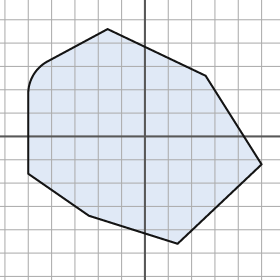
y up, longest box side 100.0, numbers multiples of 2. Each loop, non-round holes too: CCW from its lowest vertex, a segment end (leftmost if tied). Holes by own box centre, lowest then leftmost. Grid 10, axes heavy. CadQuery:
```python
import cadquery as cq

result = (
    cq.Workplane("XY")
    .moveTo(14.0, -46.0)
    .lineTo(50.0, -12.0)
    .lineTo(26.0, 26.0)
    .lineTo(-16.0, 46.0)
    .lineTo(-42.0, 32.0)
    .threePointArc((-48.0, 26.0), (-50.0, 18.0))
    .lineTo(-50.0, -16.0)
    .lineTo(-24.0, -34.0)
    .close()
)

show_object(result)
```